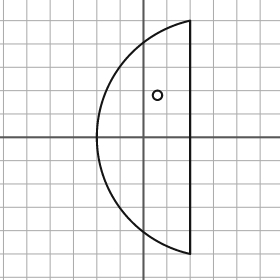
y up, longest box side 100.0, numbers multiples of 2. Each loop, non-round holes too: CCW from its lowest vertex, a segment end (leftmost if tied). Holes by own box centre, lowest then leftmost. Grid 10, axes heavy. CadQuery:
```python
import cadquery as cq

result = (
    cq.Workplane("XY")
    .moveTo(20.0, -50.0)
    .lineTo(20.0, 50.0)
    .threePointArc((-20.0, 0.0), (20.0, -50.0))
    .close()
    .moveTo(6.0, 18.0)
    .circle(2.0)
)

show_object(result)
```